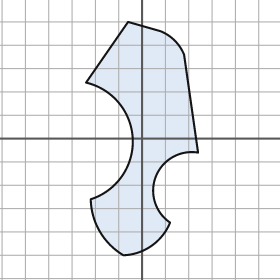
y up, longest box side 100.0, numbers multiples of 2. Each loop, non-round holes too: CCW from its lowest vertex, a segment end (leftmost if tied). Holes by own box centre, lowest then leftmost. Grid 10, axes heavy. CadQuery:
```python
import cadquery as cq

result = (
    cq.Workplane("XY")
    .moveTo(-8.0, -50.0)
    .threePointArc((4.0, -46.0), (12.0, -36.0))
    .threePointArc((6.0, -16.0), (24.0, -6.0))
    .lineTo(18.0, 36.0)
    .threePointArc((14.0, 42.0), (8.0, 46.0))
    .lineTo(-6.0, 50.0)
    .lineTo(-24.0, 24.0)
    .threePointArc((-4.0, 0.0), (-22.0, -26.0))
    .threePointArc((-18.0, -40.0), (-8.0, -50.0))
    .close()
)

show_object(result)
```